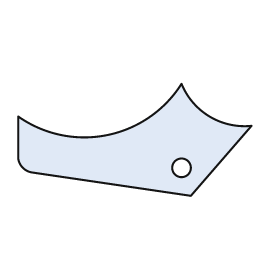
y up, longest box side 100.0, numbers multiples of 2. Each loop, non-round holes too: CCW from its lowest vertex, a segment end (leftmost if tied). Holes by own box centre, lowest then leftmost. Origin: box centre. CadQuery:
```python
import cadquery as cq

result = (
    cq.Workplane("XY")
    .moveTo(24.0, -24.0)
    .lineTo(50.0, 6.0)
    .threePointArc((32.0, 10.0), (20.0, 24.0))
    .threePointArc((-12.0, 2.0), (-50.0, 10.0))
    .lineTo(-50.0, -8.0)
    .threePointArc((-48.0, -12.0), (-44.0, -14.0))
    .close()
    .moveTo(20.0, -12.0)
    .circle(4.0)
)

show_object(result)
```